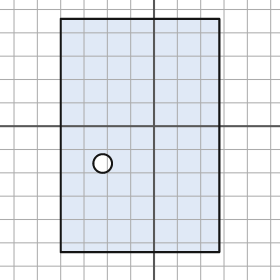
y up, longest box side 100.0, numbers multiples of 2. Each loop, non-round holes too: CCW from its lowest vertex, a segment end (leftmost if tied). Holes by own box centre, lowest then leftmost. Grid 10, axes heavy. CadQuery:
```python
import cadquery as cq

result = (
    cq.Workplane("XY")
    .moveTo(-40.0, -54.0)
    .lineTo(28.0, -54.0)
    .lineTo(28.0, 46.0)
    .lineTo(-40.0, 46.0)
    .close()
    .moveTo(-22.0, -16.0)
    .circle(4.0)
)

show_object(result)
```